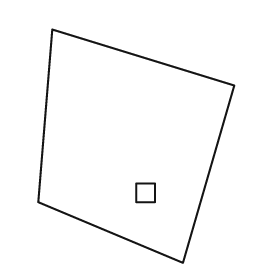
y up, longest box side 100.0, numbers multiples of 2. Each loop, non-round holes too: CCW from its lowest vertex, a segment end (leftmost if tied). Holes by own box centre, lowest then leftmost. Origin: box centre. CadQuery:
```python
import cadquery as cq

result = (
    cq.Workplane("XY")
    .moveTo(20.0, -50.0)
    .lineTo(42.0, 26.0)
    .lineTo(-36.0, 50.0)
    .lineTo(-42.0, -24.0)
    .close()
    .moveTo(0.0, -24.0)
    .lineTo(8.0, -24.0)
    .lineTo(8.0, -16.0)
    .lineTo(0.0, -16.0)
    .close()
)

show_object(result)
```